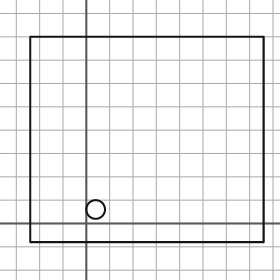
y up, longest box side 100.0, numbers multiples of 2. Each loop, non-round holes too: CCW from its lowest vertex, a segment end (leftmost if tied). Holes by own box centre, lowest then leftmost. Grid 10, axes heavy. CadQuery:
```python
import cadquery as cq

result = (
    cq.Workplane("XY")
    .moveTo(-24.0, -8.0)
    .lineTo(76.0, -8.0)
    .lineTo(76.0, 80.0)
    .lineTo(-24.0, 80.0)
    .close()
    .moveTo(4.0, 6.0)
    .circle(4.0)
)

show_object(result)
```